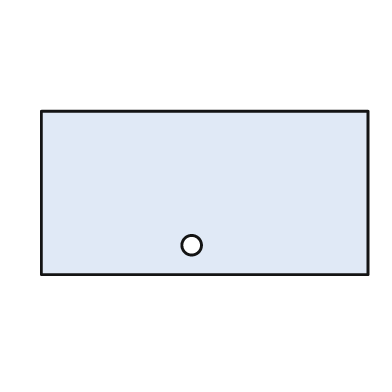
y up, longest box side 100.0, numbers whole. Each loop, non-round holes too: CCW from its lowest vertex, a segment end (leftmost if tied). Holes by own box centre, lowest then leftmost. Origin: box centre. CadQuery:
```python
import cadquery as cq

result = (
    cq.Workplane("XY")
    .moveTo(-50.0, -25.0)
    .lineTo(50.0, -25.0)
    .lineTo(50.0, 25.0)
    .lineTo(-50.0, 25.0)
    .close()
    .moveTo(-4.0, -16.0)
    .circle(3.0)
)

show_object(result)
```